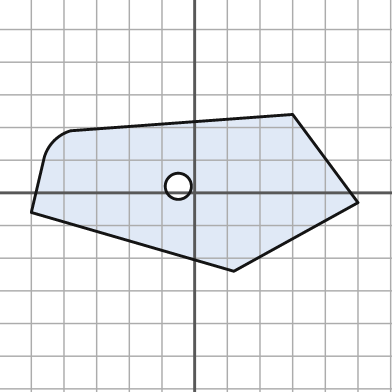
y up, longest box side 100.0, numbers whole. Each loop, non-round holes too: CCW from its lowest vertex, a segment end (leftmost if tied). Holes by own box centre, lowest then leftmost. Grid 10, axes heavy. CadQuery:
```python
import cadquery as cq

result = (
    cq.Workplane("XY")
    .moveTo(12.0, -24.0)
    .lineTo(50.0, -3.0)
    .lineTo(30.0, 24.0)
    .lineTo(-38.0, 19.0)
    .threePointArc((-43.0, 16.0), (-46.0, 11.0))
    .lineTo(-50.0, -6.0)
    .close()
    .moveTo(-5.0, 2.0)
    .circle(4.0)
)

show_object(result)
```